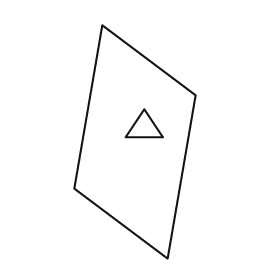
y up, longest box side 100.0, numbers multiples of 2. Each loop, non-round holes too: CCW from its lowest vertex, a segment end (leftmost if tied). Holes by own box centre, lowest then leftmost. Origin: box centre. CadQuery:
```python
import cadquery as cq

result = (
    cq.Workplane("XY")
    .moveTo(14.0, -50.0)
    .lineTo(26.0, 20.0)
    .lineTo(-14.0, 50.0)
    .lineTo(-26.0, -20.0)
    .close()
    .moveTo(-4.0, 2.0)
    .lineTo(12.0, 2.0)
    .lineTo(4.0, 14.0)
    .close()
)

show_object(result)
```